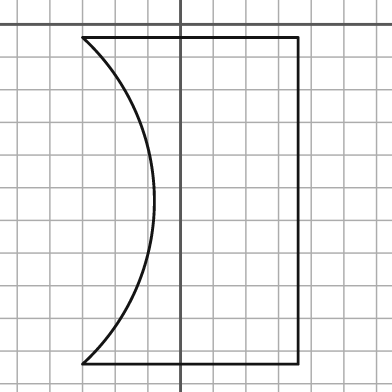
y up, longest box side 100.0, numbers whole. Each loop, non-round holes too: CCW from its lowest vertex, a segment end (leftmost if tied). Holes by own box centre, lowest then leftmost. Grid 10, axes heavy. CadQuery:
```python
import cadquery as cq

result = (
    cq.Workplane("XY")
    .moveTo(-30.0, -104.0)
    .lineTo(36.0, -104.0)
    .lineTo(36.0, -4.0)
    .lineTo(-30.0, -4.0)
    .threePointArc((-8.0, -54.0), (-30.0, -104.0))
    .close()
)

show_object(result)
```